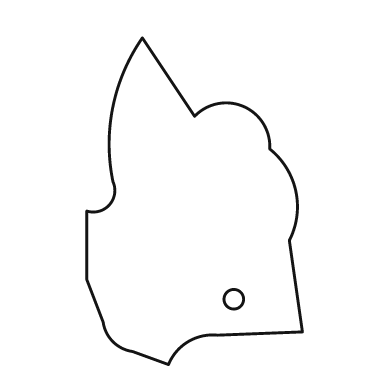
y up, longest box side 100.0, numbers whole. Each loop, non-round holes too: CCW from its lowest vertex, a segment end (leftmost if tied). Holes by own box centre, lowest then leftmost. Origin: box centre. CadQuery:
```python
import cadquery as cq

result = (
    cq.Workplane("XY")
    .moveTo(-8.0, -50.0)
    .threePointArc((-2.0, -43.0), (7.0, -41.0))
    .lineTo(33.0, -40.0)
    .lineTo(29.0, -12.0)
    .threePointArc((31.0, 3.0), (23.0, 16.0))
    .threePointArc((15.0, 29.0), (0.0, 26.0))
    .lineTo(-16.0, 50.0)
    .threePointArc((-25.0, 29.0), (-25.0, 6.0))
    .threePointArc((-26.0, -1.0), (-33.0, -3.0))
    .lineTo(-33.0, -24.0)
    .lineTo(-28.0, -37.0)
    .threePointArc((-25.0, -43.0), (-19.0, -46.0))
    .close()
    .moveTo(12.0, -30.0)
    .circle(3.0)
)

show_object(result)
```